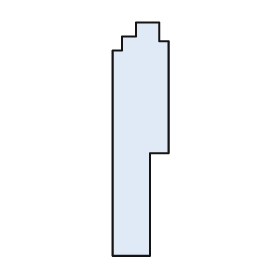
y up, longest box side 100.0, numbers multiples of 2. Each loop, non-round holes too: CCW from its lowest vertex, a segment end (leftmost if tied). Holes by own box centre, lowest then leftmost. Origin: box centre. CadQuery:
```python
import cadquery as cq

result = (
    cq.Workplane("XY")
    .moveTo(-12.0, -50.0)
    .lineTo(4.0, -50.0)
    .lineTo(4.0, -6.0)
    .lineTo(12.0, -6.0)
    .lineTo(12.0, 42.0)
    .lineTo(8.0, 42.0)
    .lineTo(8.0, 50.0)
    .lineTo(-2.0, 50.0)
    .lineTo(-2.0, 44.0)
    .lineTo(-8.0, 44.0)
    .lineTo(-8.0, 38.0)
    .lineTo(-12.0, 38.0)
    .close()
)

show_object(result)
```